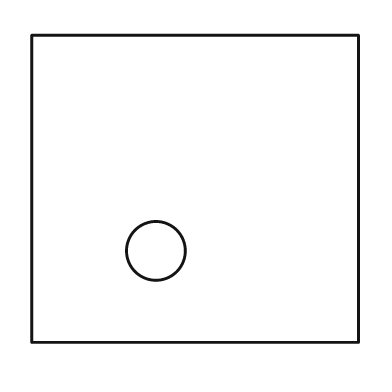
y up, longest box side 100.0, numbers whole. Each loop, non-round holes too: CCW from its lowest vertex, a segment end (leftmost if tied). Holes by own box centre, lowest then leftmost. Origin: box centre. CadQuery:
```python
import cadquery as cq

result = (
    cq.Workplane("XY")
    .moveTo(-50.0, -47.0)
    .lineTo(50.0, -47.0)
    .lineTo(50.0, 47.0)
    .lineTo(-50.0, 47.0)
    .close()
    .moveTo(-12.0, -19.0)
    .circle(9.0)
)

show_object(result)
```